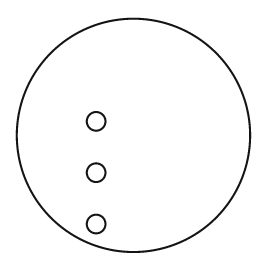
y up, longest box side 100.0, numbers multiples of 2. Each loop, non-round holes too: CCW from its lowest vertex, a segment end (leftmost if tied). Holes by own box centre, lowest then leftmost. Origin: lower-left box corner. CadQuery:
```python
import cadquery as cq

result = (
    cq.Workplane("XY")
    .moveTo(50.0, 50.0)
    .circle(50.0)
    .moveTo(34.0, 12.0)
    .circle(4.0)
    .moveTo(34.0, 34.0)
    .circle(4.0)
    .moveTo(34.0, 56.0)
    .circle(4.0)
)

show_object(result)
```